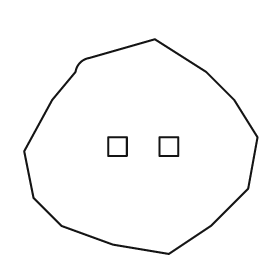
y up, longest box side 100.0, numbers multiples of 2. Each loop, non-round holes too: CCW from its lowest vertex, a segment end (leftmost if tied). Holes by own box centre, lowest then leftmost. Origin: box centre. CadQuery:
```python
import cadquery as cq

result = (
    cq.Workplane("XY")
    .moveTo(12.0, -46.0)
    .lineTo(30.0, -34.0)
    .lineTo(46.0, -18.0)
    .lineTo(50.0, 4.0)
    .lineTo(40.0, 20.0)
    .lineTo(28.0, 32.0)
    .lineTo(6.0, 46.0)
    .lineTo(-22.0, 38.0)
    .threePointArc((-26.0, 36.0), (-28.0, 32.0))
    .lineTo(-38.0, 20.0)
    .lineTo(-50.0, -2.0)
    .lineTo(-46.0, -22.0)
    .lineTo(-34.0, -34.0)
    .lineTo(-12.0, -42.0)
    .close()
    .moveTo(-14.0, -4.0)
    .lineTo(-6.0, -4.0)
    .lineTo(-6.0, 4.0)
    .lineTo(-14.0, 4.0)
    .close()
    .moveTo(8.0, -4.0)
    .lineTo(16.0, -4.0)
    .lineTo(16.0, 4.0)
    .lineTo(8.0, 4.0)
    .close()
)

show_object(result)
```